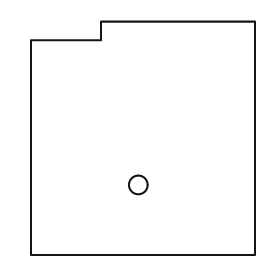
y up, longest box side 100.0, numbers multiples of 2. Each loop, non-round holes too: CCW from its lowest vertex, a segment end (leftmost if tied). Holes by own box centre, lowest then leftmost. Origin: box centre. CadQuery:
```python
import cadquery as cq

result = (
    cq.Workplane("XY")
    .moveTo(-48.0, -50.0)
    .lineTo(48.0, -50.0)
    .lineTo(48.0, 50.0)
    .lineTo(-18.0, 50.0)
    .lineTo(-18.0, 42.0)
    .lineTo(-48.0, 42.0)
    .close()
    .moveTo(-2.0, -20.0)
    .circle(4.0)
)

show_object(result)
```